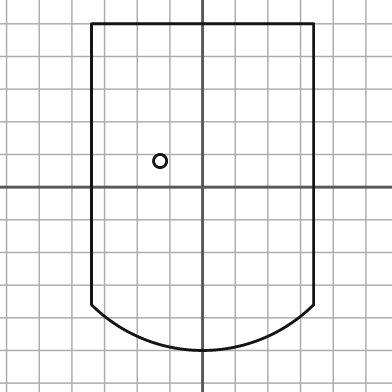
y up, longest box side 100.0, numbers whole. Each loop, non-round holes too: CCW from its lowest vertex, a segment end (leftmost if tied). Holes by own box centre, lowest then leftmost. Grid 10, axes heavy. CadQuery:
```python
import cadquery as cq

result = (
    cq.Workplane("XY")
    .moveTo(-34.0, -36.0)
    .threePointArc((0.0, -50.0), (34.0, -36.0))
    .lineTo(34.0, 50.0)
    .lineTo(-34.0, 50.0)
    .close()
    .moveTo(-13.0, 8.0)
    .circle(2.0)
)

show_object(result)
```